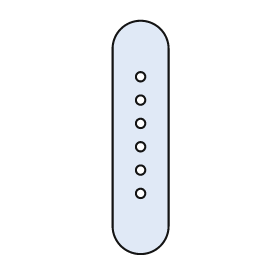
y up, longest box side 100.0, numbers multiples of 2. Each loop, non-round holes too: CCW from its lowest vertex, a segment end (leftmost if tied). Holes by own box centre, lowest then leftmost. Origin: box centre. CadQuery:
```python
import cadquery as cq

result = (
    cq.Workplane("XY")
    .moveTo(-12.0, -38.0)
    .threePointArc((0.0, -50.0), (12.0, -38.0))
    .lineTo(12.0, 38.0)
    .threePointArc((0.0, 50.0), (-12.0, 38.0))
    .close()
    .moveTo(0.0, -24.0)
    .circle(2.0)
    .moveTo(0.0, -14.0)
    .circle(2.0)
    .moveTo(0.0, -4.0)
    .circle(2.0)
    .moveTo(0.0, 6.0)
    .circle(2.0)
    .moveTo(0.0, 16.0)
    .circle(2.0)
    .moveTo(0.0, 26.0)
    .circle(2.0)
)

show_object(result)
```